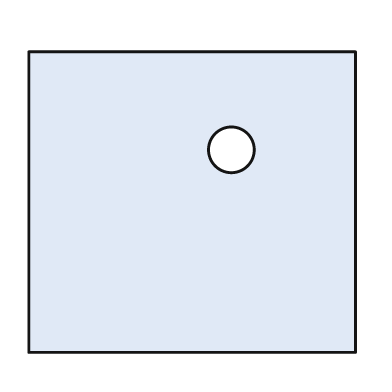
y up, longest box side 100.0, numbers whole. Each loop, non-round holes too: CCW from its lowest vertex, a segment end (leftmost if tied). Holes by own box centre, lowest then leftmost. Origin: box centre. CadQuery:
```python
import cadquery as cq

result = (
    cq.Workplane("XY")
    .moveTo(-50.0, -46.0)
    .lineTo(50.0, -46.0)
    .lineTo(50.0, 46.0)
    .lineTo(-50.0, 46.0)
    .close()
    .moveTo(12.0, 16.0)
    .circle(7.0)
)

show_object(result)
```